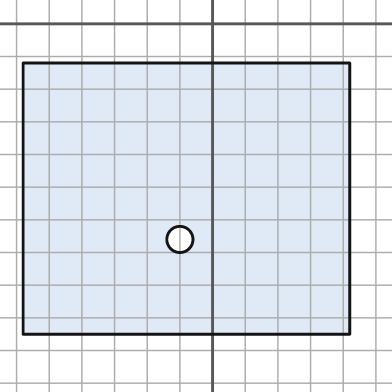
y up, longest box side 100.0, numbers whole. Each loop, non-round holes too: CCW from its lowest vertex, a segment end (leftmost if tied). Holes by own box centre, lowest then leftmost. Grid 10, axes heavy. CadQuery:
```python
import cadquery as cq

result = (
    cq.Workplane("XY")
    .moveTo(-58.0, -95.0)
    .lineTo(42.0, -95.0)
    .lineTo(42.0, -12.0)
    .lineTo(-58.0, -12.0)
    .close()
    .moveTo(-10.0, -66.0)
    .circle(4.0)
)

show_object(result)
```